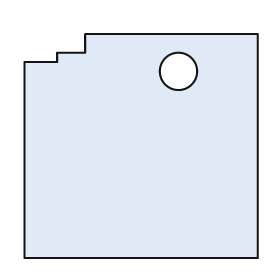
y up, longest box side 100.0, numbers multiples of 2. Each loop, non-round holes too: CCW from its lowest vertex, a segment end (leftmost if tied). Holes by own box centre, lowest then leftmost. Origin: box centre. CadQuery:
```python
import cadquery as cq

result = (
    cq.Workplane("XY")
    .moveTo(-50.0, -48.0)
    .lineTo(50.0, -48.0)
    .lineTo(50.0, 48.0)
    .lineTo(-24.0, 48.0)
    .lineTo(-24.0, 40.0)
    .lineTo(-36.0, 40.0)
    .lineTo(-36.0, 36.0)
    .lineTo(-50.0, 36.0)
    .close()
    .moveTo(16.0, 32.0)
    .circle(8.0)
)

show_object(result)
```